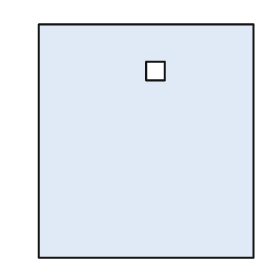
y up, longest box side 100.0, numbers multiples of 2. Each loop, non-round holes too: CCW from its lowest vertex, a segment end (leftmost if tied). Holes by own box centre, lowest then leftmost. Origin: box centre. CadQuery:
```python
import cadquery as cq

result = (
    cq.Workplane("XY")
    .moveTo(-46.0, -50.0)
    .lineTo(46.0, -50.0)
    .lineTo(46.0, 50.0)
    .lineTo(-46.0, 50.0)
    .close()
    .moveTo(0.0, 26.0)
    .lineTo(8.0, 26.0)
    .lineTo(8.0, 34.0)
    .lineTo(0.0, 34.0)
    .close()
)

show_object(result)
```